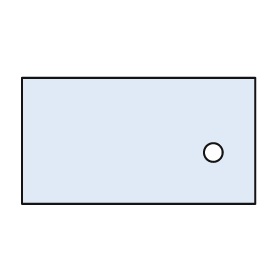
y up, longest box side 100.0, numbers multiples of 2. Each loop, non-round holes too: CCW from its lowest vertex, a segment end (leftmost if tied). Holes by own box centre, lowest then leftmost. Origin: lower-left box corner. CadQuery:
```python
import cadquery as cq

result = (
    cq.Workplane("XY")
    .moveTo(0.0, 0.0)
    .lineTo(100.0, 0.0)
    .lineTo(100.0, 54.0)
    .lineTo(0.0, 54.0)
    .close()
    .moveTo(82.0, 22.0)
    .circle(4.0)
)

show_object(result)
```